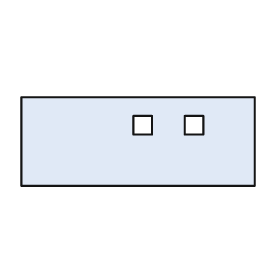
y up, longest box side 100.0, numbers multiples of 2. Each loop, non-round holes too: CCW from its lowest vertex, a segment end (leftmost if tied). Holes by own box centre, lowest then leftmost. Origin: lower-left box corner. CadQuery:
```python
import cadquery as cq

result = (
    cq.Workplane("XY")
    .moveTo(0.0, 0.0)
    .lineTo(100.0, 0.0)
    .lineTo(100.0, 38.0)
    .lineTo(0.0, 38.0)
    .close()
    .moveTo(48.0, 22.0)
    .lineTo(56.0, 22.0)
    .lineTo(56.0, 30.0)
    .lineTo(48.0, 30.0)
    .close()
    .moveTo(70.0, 22.0)
    .lineTo(78.0, 22.0)
    .lineTo(78.0, 30.0)
    .lineTo(70.0, 30.0)
    .close()
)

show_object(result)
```